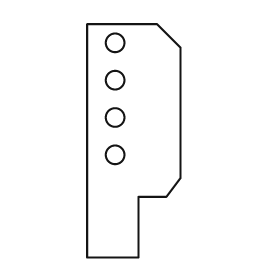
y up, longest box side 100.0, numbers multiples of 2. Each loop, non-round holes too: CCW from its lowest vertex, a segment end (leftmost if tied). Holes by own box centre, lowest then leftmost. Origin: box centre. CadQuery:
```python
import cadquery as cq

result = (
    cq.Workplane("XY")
    .moveTo(-20.0, -50.0)
    .lineTo(2.0, -50.0)
    .lineTo(2.0, -24.0)
    .lineTo(14.0, -24.0)
    .lineTo(20.0, -16.0)
    .lineTo(20.0, 40.0)
    .lineTo(10.0, 50.0)
    .lineTo(-20.0, 50.0)
    .close()
    .moveTo(-8.0, -6.0)
    .circle(4.0)
    .moveTo(-8.0, 10.0)
    .circle(4.0)
    .moveTo(-8.0, 26.0)
    .circle(4.0)
    .moveTo(-8.0, 42.0)
    .circle(4.0)
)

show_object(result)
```